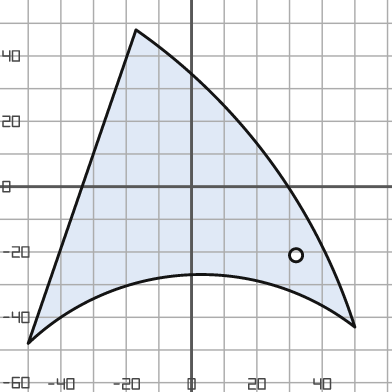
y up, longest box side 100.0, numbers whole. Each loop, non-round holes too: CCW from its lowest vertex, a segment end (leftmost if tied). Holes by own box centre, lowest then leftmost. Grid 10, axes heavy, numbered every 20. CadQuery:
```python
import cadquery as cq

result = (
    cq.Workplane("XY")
    .moveTo(-50.0, -48.0)
    .threePointArc((-1.0, -27.0), (50.0, -43.0))
    .threePointArc((24.0, 8.0), (-17.0, 48.0))
    .close()
    .moveTo(32.0, -21.0)
    .circle(2.0)
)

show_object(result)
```